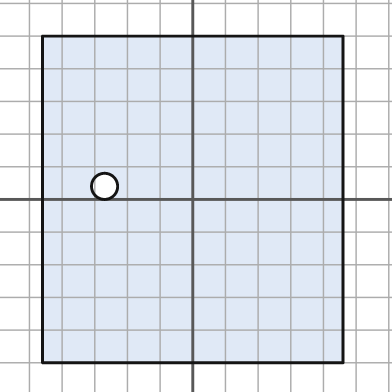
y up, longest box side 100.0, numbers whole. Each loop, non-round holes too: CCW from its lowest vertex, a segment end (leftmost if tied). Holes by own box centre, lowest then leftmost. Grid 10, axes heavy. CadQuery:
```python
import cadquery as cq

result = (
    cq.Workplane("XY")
    .moveTo(-46.0, -50.0)
    .lineTo(46.0, -50.0)
    .lineTo(46.0, 50.0)
    .lineTo(-46.0, 50.0)
    .close()
    .moveTo(-27.0, 4.0)
    .circle(4.0)
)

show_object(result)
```